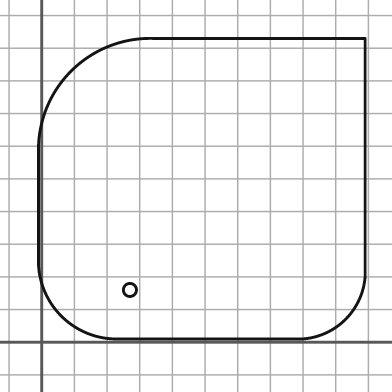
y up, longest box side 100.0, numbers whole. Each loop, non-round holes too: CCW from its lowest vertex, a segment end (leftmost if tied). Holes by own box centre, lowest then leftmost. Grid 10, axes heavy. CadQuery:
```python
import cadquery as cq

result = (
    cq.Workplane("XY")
    .moveTo(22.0, 1.0)
    .lineTo(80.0, 1.0)
    .threePointArc((93.0, 7.0), (99.0, 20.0))
    .lineTo(99.0, 93.0)
    .lineTo(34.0, 93.0)
    .threePointArc((9.0, 83.0), (-1.0, 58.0))
    .lineTo(-1.0, 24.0)
    .threePointArc((6.0, 8.0), (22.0, 1.0))
    .close()
    .moveTo(27.0, 16.0)
    .circle(2.0)
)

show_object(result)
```